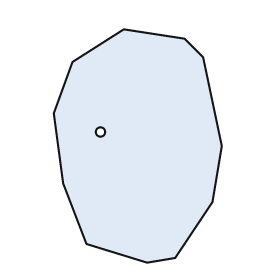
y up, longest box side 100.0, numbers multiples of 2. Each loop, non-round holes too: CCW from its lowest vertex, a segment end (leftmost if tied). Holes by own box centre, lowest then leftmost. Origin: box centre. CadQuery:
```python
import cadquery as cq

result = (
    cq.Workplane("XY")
    .moveTo(4.0, -50.0)
    .lineTo(16.0, -48.0)
    .lineTo(32.0, -24.0)
    .lineTo(36.0, 0.0)
    .lineTo(28.0, 38.0)
    .lineTo(20.0, 46.0)
    .lineTo(-6.0, 50.0)
    .lineTo(-28.0, 36.0)
    .lineTo(-36.0, 14.0)
    .lineTo(-32.0, -16.0)
    .lineTo(-22.0, -42.0)
    .close()
    .moveTo(-16.0, 6.0)
    .circle(2.0)
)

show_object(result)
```